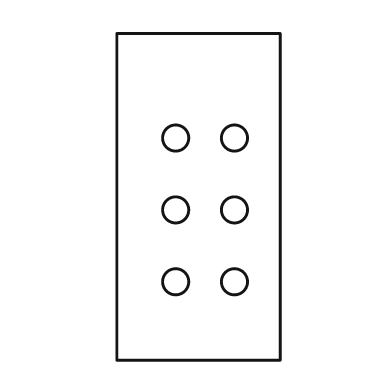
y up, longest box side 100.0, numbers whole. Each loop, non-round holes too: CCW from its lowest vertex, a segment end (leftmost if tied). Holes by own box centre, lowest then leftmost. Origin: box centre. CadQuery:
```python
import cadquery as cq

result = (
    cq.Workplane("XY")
    .moveTo(-25.0, -50.0)
    .lineTo(25.0, -50.0)
    .lineTo(25.0, 50.0)
    .lineTo(-25.0, 50.0)
    .close()
    .moveTo(-7.0, -26.0)
    .circle(4.0)
    .moveTo(11.0, -26.0)
    .circle(4.0)
    .moveTo(-7.0, -4.0)
    .circle(4.0)
    .moveTo(11.0, -4.0)
    .circle(4.0)
    .moveTo(-7.0, 18.0)
    .circle(4.0)
    .moveTo(11.0, 18.0)
    .circle(4.0)
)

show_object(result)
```